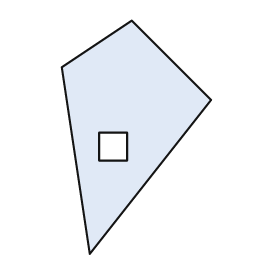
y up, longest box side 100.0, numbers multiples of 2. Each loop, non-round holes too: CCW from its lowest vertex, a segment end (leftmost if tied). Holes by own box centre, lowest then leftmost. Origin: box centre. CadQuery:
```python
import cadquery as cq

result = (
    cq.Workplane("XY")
    .moveTo(-20.0, -50.0)
    .lineTo(32.0, 16.0)
    .lineTo(-2.0, 50.0)
    .lineTo(-32.0, 30.0)
    .close()
    .moveTo(-16.0, -10.0)
    .lineTo(-4.0, -10.0)
    .lineTo(-4.0, 2.0)
    .lineTo(-16.0, 2.0)
    .close()
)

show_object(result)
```